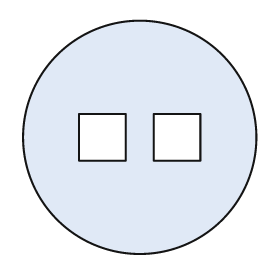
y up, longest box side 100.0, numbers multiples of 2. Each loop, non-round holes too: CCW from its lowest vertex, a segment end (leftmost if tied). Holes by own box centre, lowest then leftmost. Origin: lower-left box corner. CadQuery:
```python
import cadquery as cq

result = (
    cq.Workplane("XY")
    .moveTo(50.0, 50.0)
    .circle(50.0)
    .moveTo(24.0, 40.0)
    .lineTo(44.0, 40.0)
    .lineTo(44.0, 60.0)
    .lineTo(24.0, 60.0)
    .close()
    .moveTo(56.0, 40.0)
    .lineTo(76.0, 40.0)
    .lineTo(76.0, 60.0)
    .lineTo(56.0, 60.0)
    .close()
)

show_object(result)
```